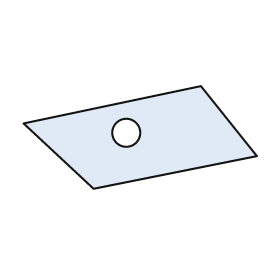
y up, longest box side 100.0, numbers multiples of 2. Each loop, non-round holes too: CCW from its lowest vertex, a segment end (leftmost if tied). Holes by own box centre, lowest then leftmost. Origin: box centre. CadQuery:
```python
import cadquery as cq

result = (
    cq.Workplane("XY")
    .moveTo(-20.0, -22.0)
    .lineTo(50.0, -8.0)
    .lineTo(26.0, 22.0)
    .lineTo(-50.0, 6.0)
    .close()
    .moveTo(-6.0, 2.0)
    .circle(6.0)
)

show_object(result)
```